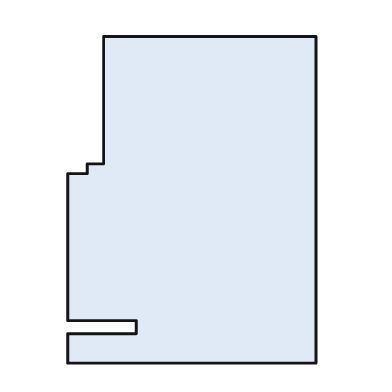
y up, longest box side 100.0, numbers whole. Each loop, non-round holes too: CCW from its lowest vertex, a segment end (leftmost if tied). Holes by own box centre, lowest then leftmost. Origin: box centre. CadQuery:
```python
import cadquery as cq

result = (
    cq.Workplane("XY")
    .moveTo(-38.0, -50.0)
    .lineTo(38.0, -50.0)
    .lineTo(38.0, 50.0)
    .lineTo(-27.0, 50.0)
    .lineTo(-27.0, 11.0)
    .lineTo(-32.0, 11.0)
    .lineTo(-32.0, 8.0)
    .lineTo(-38.0, 8.0)
    .lineTo(-38.0, -37.0)
    .lineTo(-17.0, -37.0)
    .lineTo(-17.0, -41.0)
    .lineTo(-38.0, -41.0)
    .close()
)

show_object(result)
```